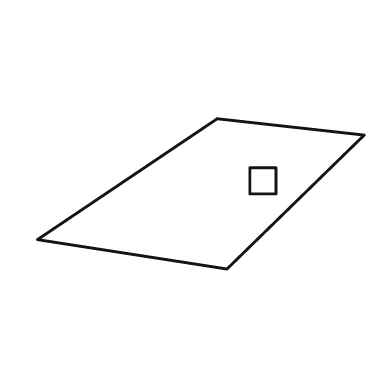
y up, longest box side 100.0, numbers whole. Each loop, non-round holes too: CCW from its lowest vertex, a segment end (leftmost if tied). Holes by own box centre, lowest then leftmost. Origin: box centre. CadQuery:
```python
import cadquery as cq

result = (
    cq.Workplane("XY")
    .moveTo(8.0, -23.0)
    .lineTo(50.0, 18.0)
    .lineTo(5.0, 23.0)
    .lineTo(-50.0, -14.0)
    .close()
    .moveTo(15.0, 0.0)
    .lineTo(23.0, 0.0)
    .lineTo(23.0, 8.0)
    .lineTo(15.0, 8.0)
    .close()
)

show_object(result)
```